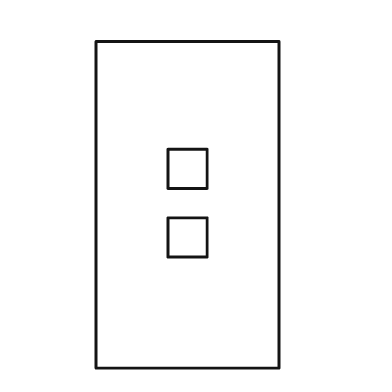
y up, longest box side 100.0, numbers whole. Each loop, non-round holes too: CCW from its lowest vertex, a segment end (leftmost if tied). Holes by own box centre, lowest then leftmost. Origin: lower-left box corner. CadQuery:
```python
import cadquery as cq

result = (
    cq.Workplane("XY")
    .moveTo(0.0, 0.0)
    .lineTo(56.0, 0.0)
    .lineTo(56.0, 100.0)
    .lineTo(0.0, 100.0)
    .close()
    .moveTo(22.0, 34.0)
    .lineTo(34.0, 34.0)
    .lineTo(34.0, 46.0)
    .lineTo(22.0, 46.0)
    .close()
    .moveTo(22.0, 55.0)
    .lineTo(34.0, 55.0)
    .lineTo(34.0, 67.0)
    .lineTo(22.0, 67.0)
    .close()
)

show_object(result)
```